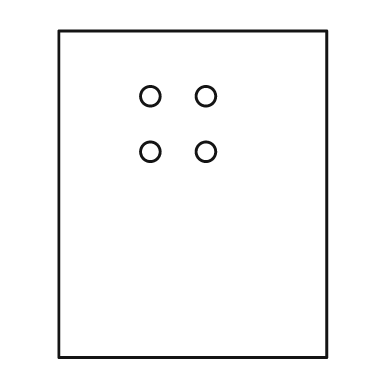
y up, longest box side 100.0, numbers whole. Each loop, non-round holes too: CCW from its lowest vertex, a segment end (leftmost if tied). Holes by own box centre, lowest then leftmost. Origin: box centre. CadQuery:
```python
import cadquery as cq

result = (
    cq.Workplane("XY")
    .moveTo(-41.0, -50.0)
    .lineTo(41.0, -50.0)
    .lineTo(41.0, 50.0)
    .lineTo(-41.0, 50.0)
    .close()
    .moveTo(-13.0, 13.0)
    .circle(3.0)
    .moveTo(4.0, 13.0)
    .circle(3.0)
    .moveTo(-13.0, 30.0)
    .circle(3.0)
    .moveTo(4.0, 30.0)
    .circle(3.0)
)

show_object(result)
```